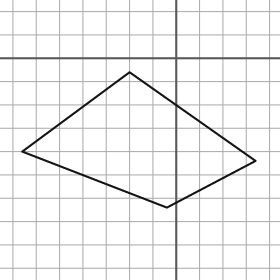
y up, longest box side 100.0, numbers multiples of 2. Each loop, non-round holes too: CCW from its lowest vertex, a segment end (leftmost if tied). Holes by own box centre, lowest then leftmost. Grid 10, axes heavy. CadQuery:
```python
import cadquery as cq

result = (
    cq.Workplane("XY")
    .moveTo(-4.0, -64.0)
    .lineTo(34.0, -44.0)
    .lineTo(-20.0, -6.0)
    .lineTo(-66.0, -40.0)
    .close()
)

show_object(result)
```